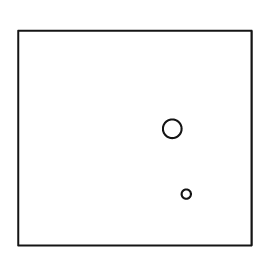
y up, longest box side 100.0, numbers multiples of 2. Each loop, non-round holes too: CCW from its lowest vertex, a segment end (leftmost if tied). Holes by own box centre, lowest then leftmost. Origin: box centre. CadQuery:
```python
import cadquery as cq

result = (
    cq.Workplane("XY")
    .moveTo(-50.0, -46.0)
    .lineTo(50.0, -46.0)
    .lineTo(50.0, 46.0)
    .lineTo(-50.0, 46.0)
    .close()
    .moveTo(22.0, -24.0)
    .circle(2.0)
    .moveTo(16.0, 4.0)
    .circle(4.0)
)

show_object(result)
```